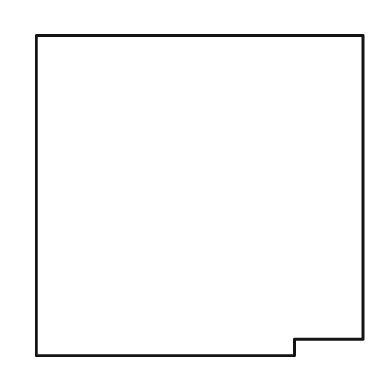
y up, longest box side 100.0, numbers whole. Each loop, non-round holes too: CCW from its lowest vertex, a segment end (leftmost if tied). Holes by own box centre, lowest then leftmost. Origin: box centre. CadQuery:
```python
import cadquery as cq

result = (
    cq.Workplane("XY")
    .moveTo(-50.0, -49.0)
    .lineTo(29.0, -49.0)
    .lineTo(29.0, -44.0)
    .lineTo(50.0, -44.0)
    .lineTo(50.0, 49.0)
    .lineTo(-50.0, 49.0)
    .close()
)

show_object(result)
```